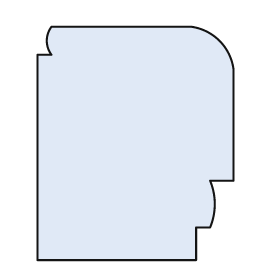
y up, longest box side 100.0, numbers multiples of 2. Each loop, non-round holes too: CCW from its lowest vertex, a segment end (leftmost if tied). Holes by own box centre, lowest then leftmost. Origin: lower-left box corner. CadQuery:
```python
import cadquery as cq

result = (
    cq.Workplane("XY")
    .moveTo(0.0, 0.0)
    .lineTo(68.0, 0.0)
    .lineTo(68.0, 14.0)
    .lineTo(74.0, 14.0)
    .threePointArc((76.0, 24.0), (74.0, 34.0))
    .lineTo(84.0, 34.0)
    .lineTo(84.0, 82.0)
    .threePointArc((78.0, 94.0), (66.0, 100.0))
    .lineTo(6.0, 100.0)
    .threePointArc((4.0, 94.0), (6.0, 88.0))
    .lineTo(0.0, 88.0)
    .close()
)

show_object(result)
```